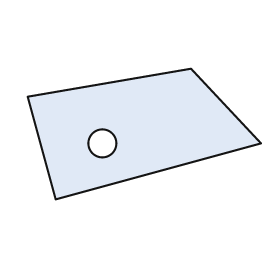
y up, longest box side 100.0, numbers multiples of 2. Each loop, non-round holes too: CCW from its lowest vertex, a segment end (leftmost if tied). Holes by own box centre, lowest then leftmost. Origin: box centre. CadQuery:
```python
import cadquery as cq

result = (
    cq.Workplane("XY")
    .moveTo(-38.0, -28.0)
    .lineTo(50.0, -4.0)
    .lineTo(20.0, 28.0)
    .lineTo(-50.0, 16.0)
    .close()
    .moveTo(-18.0, -4.0)
    .circle(6.0)
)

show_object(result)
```